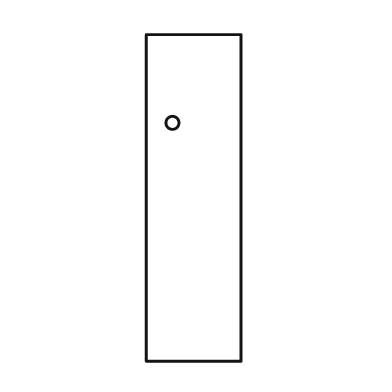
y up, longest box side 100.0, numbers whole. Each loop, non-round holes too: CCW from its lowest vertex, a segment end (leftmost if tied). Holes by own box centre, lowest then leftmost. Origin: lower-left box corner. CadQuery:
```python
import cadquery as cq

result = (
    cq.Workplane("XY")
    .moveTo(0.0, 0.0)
    .lineTo(29.0, 0.0)
    .lineTo(29.0, 100.0)
    .lineTo(0.0, 100.0)
    .close()
    .moveTo(8.0, 73.0)
    .circle(2.0)
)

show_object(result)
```